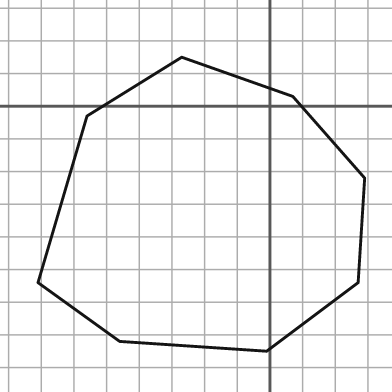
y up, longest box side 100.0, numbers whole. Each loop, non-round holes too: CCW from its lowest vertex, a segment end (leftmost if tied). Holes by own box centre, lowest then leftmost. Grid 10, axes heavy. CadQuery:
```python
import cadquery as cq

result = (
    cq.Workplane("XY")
    .moveTo(-1.0, -75.0)
    .lineTo(27.0, -54.0)
    .lineTo(29.0, -22.0)
    .lineTo(7.0, 3.0)
    .lineTo(-27.0, 15.0)
    .lineTo(-56.0, -3.0)
    .lineTo(-71.0, -54.0)
    .lineTo(-46.0, -72.0)
    .close()
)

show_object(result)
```